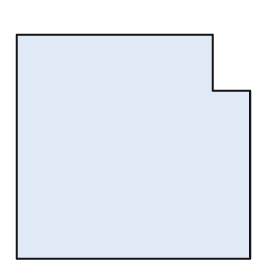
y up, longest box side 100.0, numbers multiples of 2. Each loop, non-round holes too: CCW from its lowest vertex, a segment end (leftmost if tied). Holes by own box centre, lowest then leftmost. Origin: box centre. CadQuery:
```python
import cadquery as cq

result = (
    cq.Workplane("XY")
    .moveTo(-50.0, -48.0)
    .lineTo(50.0, -48.0)
    .lineTo(50.0, 24.0)
    .lineTo(34.0, 24.0)
    .lineTo(34.0, 48.0)
    .lineTo(-50.0, 48.0)
    .close()
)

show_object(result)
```